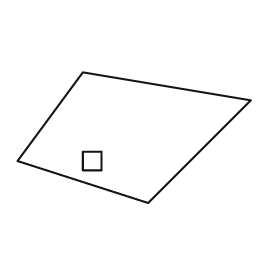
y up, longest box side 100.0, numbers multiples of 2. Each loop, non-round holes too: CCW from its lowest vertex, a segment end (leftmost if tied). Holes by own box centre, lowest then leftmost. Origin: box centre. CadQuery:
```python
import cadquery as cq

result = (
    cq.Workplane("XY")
    .moveTo(6.0, -28.0)
    .lineTo(50.0, 16.0)
    .lineTo(-22.0, 28.0)
    .lineTo(-50.0, -10.0)
    .close()
    .moveTo(-22.0, -14.0)
    .lineTo(-14.0, -14.0)
    .lineTo(-14.0, -6.0)
    .lineTo(-22.0, -6.0)
    .close()
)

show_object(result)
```